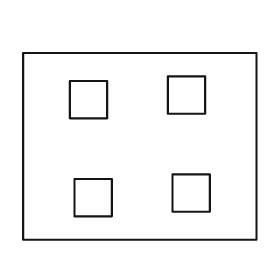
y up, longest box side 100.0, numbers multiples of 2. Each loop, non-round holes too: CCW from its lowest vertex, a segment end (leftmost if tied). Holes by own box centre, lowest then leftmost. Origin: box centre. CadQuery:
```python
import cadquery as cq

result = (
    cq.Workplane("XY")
    .moveTo(-50.0, -40.0)
    .lineTo(50.0, -40.0)
    .lineTo(50.0, 40.0)
    .lineTo(-50.0, 40.0)
    .close()
    .moveTo(-28.0, -30.0)
    .lineTo(-12.0, -30.0)
    .lineTo(-12.0, -14.0)
    .lineTo(-28.0, -14.0)
    .close()
    .moveTo(14.0, -28.0)
    .lineTo(30.0, -28.0)
    .lineTo(30.0, -12.0)
    .lineTo(14.0, -12.0)
    .close()
    .moveTo(-30.0, 12.0)
    .lineTo(-14.0, 12.0)
    .lineTo(-14.0, 28.0)
    .lineTo(-30.0, 28.0)
    .close()
    .moveTo(12.0, 14.0)
    .lineTo(28.0, 14.0)
    .lineTo(28.0, 30.0)
    .lineTo(12.0, 30.0)
    .close()
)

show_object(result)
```